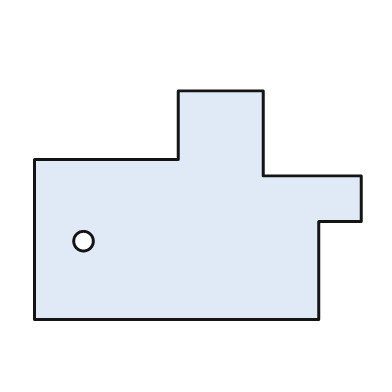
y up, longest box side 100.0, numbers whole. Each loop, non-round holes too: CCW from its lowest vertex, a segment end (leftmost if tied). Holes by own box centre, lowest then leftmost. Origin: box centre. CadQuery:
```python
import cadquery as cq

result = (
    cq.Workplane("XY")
    .moveTo(-50.0, -35.0)
    .lineTo(37.0, -35.0)
    .lineTo(37.0, -5.0)
    .lineTo(50.0, -5.0)
    .lineTo(50.0, 9.0)
    .lineTo(20.0, 9.0)
    .lineTo(20.0, 35.0)
    .lineTo(-6.0, 35.0)
    .lineTo(-6.0, 14.0)
    .lineTo(-50.0, 14.0)
    .close()
    .moveTo(-35.0, -11.0)
    .circle(3.0)
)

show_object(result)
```